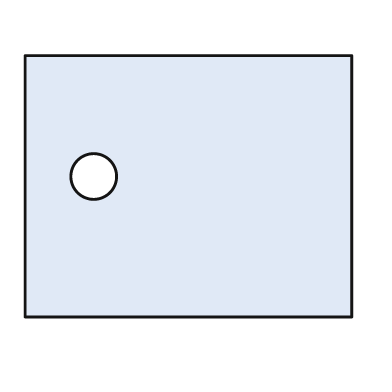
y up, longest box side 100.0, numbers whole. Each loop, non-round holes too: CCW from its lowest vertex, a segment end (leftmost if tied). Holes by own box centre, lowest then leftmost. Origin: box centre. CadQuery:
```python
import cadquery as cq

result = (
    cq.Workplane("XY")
    .moveTo(-50.0, -40.0)
    .lineTo(50.0, -40.0)
    .lineTo(50.0, 40.0)
    .lineTo(-50.0, 40.0)
    .close()
    .moveTo(-29.0, 3.0)
    .circle(7.0)
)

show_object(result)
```